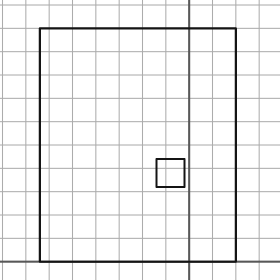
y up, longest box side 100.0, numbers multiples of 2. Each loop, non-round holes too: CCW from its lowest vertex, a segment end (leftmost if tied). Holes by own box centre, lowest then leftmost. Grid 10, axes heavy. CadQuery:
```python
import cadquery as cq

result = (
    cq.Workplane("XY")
    .moveTo(-64.0, 0.0)
    .lineTo(20.0, 0.0)
    .lineTo(20.0, 100.0)
    .lineTo(-64.0, 100.0)
    .close()
    .moveTo(-14.0, 32.0)
    .lineTo(-2.0, 32.0)
    .lineTo(-2.0, 44.0)
    .lineTo(-14.0, 44.0)
    .close()
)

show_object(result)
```